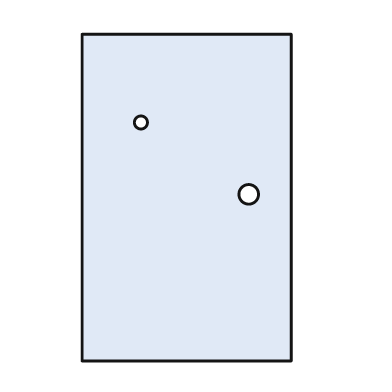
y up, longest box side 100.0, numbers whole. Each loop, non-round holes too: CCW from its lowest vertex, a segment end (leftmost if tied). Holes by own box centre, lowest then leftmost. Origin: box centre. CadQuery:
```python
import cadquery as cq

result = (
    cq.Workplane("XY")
    .moveTo(-32.0, -50.0)
    .lineTo(32.0, -50.0)
    .lineTo(32.0, 50.0)
    .lineTo(-32.0, 50.0)
    .close()
    .moveTo(19.0, 1.0)
    .circle(3.0)
    .moveTo(-14.0, 23.0)
    .circle(2.0)
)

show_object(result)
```